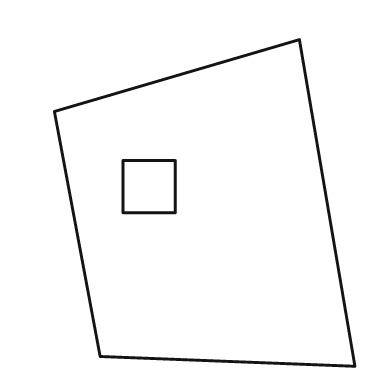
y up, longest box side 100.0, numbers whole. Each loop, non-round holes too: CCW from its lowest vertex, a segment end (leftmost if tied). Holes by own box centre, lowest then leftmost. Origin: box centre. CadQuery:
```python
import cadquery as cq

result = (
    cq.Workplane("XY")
    .moveTo(46.0, -50.0)
    .lineTo(29.0, 50.0)
    .lineTo(-46.0, 28.0)
    .lineTo(-32.0, -47.0)
    .close()
    .moveTo(-25.0, -3.0)
    .lineTo(-9.0, -3.0)
    .lineTo(-9.0, 13.0)
    .lineTo(-25.0, 13.0)
    .close()
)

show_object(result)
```